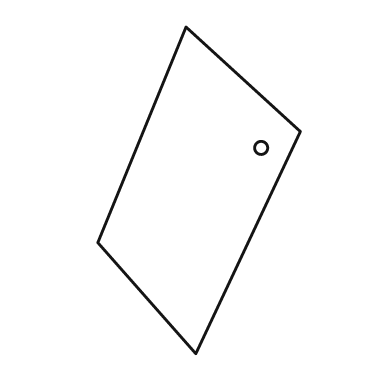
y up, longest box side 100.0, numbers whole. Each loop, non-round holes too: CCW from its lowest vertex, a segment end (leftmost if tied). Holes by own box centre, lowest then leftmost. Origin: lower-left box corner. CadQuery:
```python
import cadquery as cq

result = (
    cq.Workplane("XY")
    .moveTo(30.0, 0.0)
    .lineTo(62.0, 68.0)
    .lineTo(27.0, 100.0)
    .lineTo(0.0, 34.0)
    .close()
    .moveTo(50.0, 63.0)
    .circle(2.0)
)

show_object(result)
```